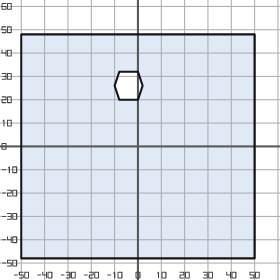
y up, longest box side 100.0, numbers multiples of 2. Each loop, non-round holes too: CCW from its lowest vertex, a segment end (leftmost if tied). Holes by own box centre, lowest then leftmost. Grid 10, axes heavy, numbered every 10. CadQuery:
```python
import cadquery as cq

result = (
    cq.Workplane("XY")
    .moveTo(-50.0, -48.0)
    .lineTo(50.0, -48.0)
    .lineTo(50.0, 48.0)
    .lineTo(-50.0, 48.0)
    .close()
    .moveTo(-8.0, 20.0)
    .lineTo(0.0, 20.0)
    .lineTo(2.0, 26.0)
    .lineTo(0.0, 32.0)
    .lineTo(-8.0, 32.0)
    .lineTo(-10.0, 26.0)
    .close()
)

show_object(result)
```